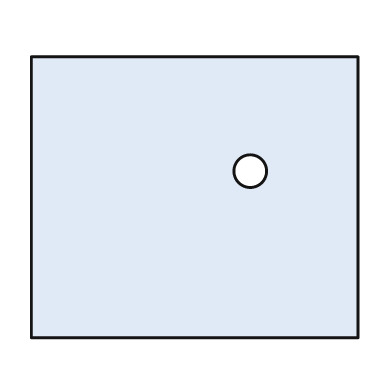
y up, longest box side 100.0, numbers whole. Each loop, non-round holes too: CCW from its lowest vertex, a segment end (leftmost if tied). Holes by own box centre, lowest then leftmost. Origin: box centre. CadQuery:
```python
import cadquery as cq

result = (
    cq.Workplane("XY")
    .moveTo(-50.0, -43.0)
    .lineTo(50.0, -43.0)
    .lineTo(50.0, 43.0)
    .lineTo(-50.0, 43.0)
    .close()
    .moveTo(17.0, 8.0)
    .circle(5.0)
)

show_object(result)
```